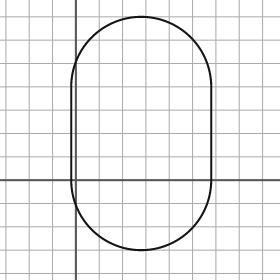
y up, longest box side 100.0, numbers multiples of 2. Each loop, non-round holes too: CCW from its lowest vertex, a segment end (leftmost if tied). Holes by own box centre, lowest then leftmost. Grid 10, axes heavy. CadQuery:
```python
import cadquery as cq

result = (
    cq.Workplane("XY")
    .moveTo(-2.0, 0.0)
    .threePointArc((28.0, -30.0), (58.0, 0.0))
    .lineTo(58.0, 40.0)
    .threePointArc((28.0, 70.0), (-2.0, 40.0))
    .close()
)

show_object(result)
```